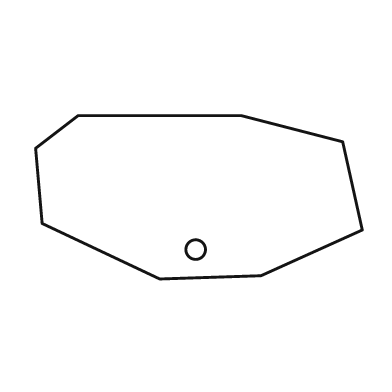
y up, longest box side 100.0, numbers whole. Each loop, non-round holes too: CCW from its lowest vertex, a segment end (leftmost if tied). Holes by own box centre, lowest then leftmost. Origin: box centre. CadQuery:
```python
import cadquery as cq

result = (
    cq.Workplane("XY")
    .moveTo(-12.0, -25.0)
    .lineTo(19.0, -24.0)
    .lineTo(50.0, -10.0)
    .lineTo(44.0, 17.0)
    .lineTo(13.0, 25.0)
    .lineTo(-37.0, 25.0)
    .lineTo(-50.0, 15.0)
    .lineTo(-48.0, -8.0)
    .close()
    .moveTo(-1.0, -16.0)
    .circle(3.0)
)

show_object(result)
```